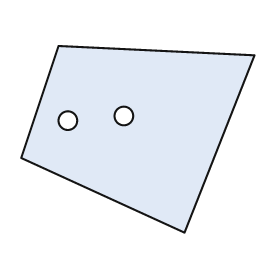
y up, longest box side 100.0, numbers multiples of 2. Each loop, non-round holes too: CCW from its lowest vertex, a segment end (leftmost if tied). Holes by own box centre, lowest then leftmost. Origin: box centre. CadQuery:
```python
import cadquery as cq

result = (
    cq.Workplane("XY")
    .moveTo(20.0, -40.0)
    .lineTo(50.0, 36.0)
    .lineTo(-34.0, 40.0)
    .lineTo(-50.0, -8.0)
    .close()
    .moveTo(-30.0, 8.0)
    .circle(4.0)
    .moveTo(-6.0, 10.0)
    .circle(4.0)
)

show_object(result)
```